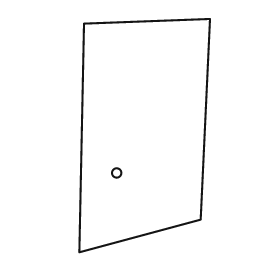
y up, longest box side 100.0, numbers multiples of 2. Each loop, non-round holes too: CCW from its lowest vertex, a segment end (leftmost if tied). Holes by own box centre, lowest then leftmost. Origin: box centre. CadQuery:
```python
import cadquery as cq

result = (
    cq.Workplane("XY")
    .moveTo(-28.0, -50.0)
    .lineTo(24.0, -36.0)
    .lineTo(28.0, 50.0)
    .lineTo(-26.0, 48.0)
    .close()
    .moveTo(-12.0, -16.0)
    .circle(2.0)
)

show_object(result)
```